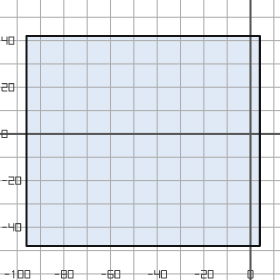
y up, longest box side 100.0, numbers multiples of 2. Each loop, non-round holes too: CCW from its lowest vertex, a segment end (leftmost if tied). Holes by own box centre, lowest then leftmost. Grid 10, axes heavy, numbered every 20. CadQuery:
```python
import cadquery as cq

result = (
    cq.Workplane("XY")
    .moveTo(-96.0, -48.0)
    .lineTo(4.0, -48.0)
    .lineTo(4.0, 42.0)
    .lineTo(-96.0, 42.0)
    .close()
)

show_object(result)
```